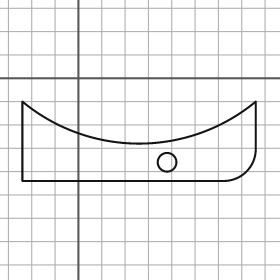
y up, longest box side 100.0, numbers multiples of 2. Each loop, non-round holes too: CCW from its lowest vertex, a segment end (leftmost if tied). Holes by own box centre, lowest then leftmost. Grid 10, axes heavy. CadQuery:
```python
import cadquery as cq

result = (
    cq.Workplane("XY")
    .moveTo(-24.0, -44.0)
    .lineTo(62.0, -44.0)
    .threePointArc((72.0, -40.0), (76.0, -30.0))
    .lineTo(76.0, -10.0)
    .threePointArc((26.0, -28.0), (-24.0, -10.0))
    .close()
    .moveTo(38.0, -36.0)
    .circle(4.0)
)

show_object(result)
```